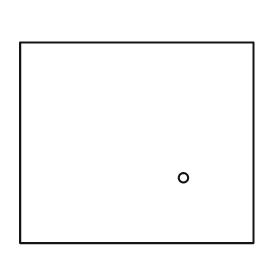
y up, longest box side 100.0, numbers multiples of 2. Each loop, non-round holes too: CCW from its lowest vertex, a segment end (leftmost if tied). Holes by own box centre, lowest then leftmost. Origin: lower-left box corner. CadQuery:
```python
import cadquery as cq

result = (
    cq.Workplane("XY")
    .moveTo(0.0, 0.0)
    .lineTo(100.0, 0.0)
    .lineTo(100.0, 86.0)
    .lineTo(0.0, 86.0)
    .close()
    .moveTo(70.0, 28.0)
    .circle(2.0)
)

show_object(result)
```